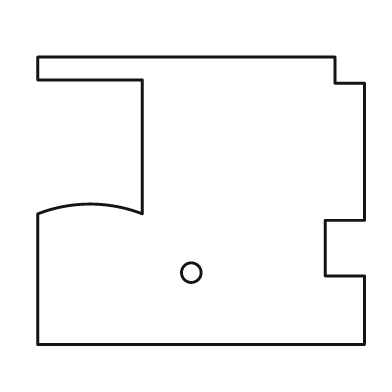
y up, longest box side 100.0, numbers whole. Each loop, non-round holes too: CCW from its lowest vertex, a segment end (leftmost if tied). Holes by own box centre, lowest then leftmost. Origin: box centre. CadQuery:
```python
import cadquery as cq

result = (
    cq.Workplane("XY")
    .moveTo(-50.0, -44.0)
    .lineTo(50.0, -44.0)
    .lineTo(50.0, -23.0)
    .lineTo(38.0, -23.0)
    .lineTo(38.0, -6.0)
    .lineTo(50.0, -6.0)
    .lineTo(50.0, 36.0)
    .lineTo(41.0, 36.0)
    .lineTo(41.0, 44.0)
    .lineTo(-50.0, 44.0)
    .lineTo(-50.0, 37.0)
    .lineTo(-18.0, 37.0)
    .lineTo(-18.0, -4.0)
    .threePointArc((-34.0, -1.0), (-50.0, -4.0))
    .close()
    .moveTo(-3.0, -22.0)
    .circle(3.0)
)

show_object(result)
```